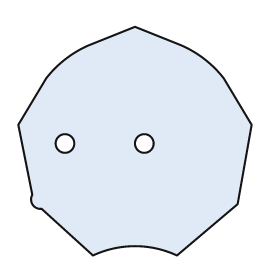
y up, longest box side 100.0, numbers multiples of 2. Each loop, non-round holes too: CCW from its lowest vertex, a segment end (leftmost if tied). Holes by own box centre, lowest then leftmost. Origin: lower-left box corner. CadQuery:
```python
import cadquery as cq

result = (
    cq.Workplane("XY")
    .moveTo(32.0, 0.0)
    .threePointArc((50.0, 4.0), (68.0, 0.0))
    .lineTo(94.0, 22.0)
    .lineTo(100.0, 56.0)
    .lineTo(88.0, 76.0)
    .threePointArc((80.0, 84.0), (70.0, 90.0))
    .lineTo(50.0, 98.0)
    .lineTo(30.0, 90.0)
    .threePointArc((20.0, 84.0), (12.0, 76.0))
    .lineTo(0.0, 56.0)
    .lineTo(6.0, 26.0)
    .threePointArc((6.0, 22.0), (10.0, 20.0))
    .close()
    .moveTo(20.0, 48.0)
    .circle(4.0)
    .moveTo(54.0, 48.0)
    .circle(4.0)
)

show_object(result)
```